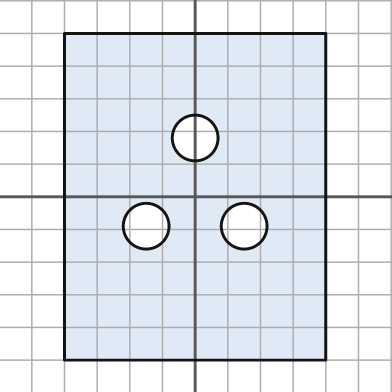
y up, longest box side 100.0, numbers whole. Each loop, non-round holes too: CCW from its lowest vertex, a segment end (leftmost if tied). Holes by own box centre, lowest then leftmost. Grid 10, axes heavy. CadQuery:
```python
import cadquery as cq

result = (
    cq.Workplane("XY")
    .moveTo(-40.0, -50.0)
    .lineTo(40.0, -50.0)
    .lineTo(40.0, 50.0)
    .lineTo(-40.0, 50.0)
    .close()
    .moveTo(-15.0, -9.0)
    .circle(7.0)
    .moveTo(15.0, -9.0)
    .circle(7.0)
    .moveTo(0.0, 18.0)
    .circle(7.0)
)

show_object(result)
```